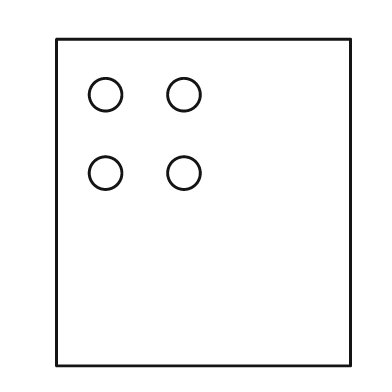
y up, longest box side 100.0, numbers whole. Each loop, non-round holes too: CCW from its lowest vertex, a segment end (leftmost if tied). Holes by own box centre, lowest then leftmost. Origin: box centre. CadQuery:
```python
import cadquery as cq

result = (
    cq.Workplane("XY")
    .moveTo(-45.0, -50.0)
    .lineTo(45.0, -50.0)
    .lineTo(45.0, 50.0)
    .lineTo(-45.0, 50.0)
    .close()
    .moveTo(-30.0, 9.0)
    .circle(5.0)
    .moveTo(-6.0, 9.0)
    .circle(5.0)
    .moveTo(-30.0, 33.0)
    .circle(5.0)
    .moveTo(-6.0, 33.0)
    .circle(5.0)
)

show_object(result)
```